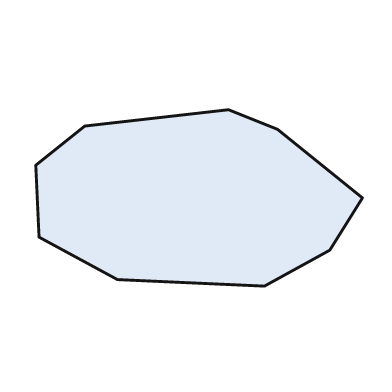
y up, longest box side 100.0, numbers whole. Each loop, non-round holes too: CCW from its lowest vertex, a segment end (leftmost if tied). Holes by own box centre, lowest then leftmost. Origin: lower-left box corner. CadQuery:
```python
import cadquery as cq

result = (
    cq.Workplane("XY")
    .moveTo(70.0, 0.0)
    .lineTo(90.0, 11.0)
    .lineTo(100.0, 27.0)
    .lineTo(74.0, 48.0)
    .lineTo(59.0, 54.0)
    .lineTo(15.0, 49.0)
    .lineTo(0.0, 37.0)
    .lineTo(1.0, 15.0)
    .lineTo(25.0, 2.0)
    .close()
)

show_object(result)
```